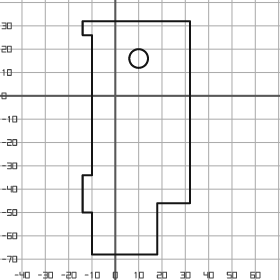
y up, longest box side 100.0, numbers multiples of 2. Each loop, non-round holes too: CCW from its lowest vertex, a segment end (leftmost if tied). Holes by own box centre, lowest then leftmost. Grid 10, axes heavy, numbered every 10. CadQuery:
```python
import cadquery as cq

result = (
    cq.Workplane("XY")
    .moveTo(-10.0, -68.0)
    .lineTo(18.0, -68.0)
    .lineTo(18.0, -46.0)
    .lineTo(32.0, -46.0)
    .lineTo(32.0, 32.0)
    .lineTo(-14.0, 32.0)
    .lineTo(-14.0, 26.0)
    .lineTo(-10.0, 26.0)
    .lineTo(-10.0, -34.0)
    .lineTo(-14.0, -34.0)
    .lineTo(-14.0, -50.0)
    .lineTo(-10.0, -50.0)
    .close()
    .moveTo(10.0, 16.0)
    .circle(4.0)
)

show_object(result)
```